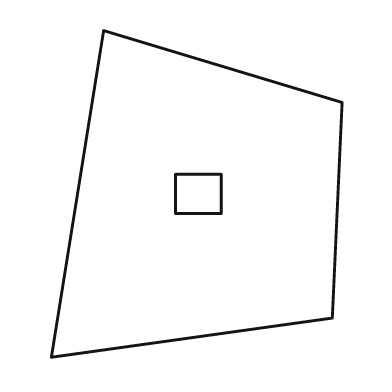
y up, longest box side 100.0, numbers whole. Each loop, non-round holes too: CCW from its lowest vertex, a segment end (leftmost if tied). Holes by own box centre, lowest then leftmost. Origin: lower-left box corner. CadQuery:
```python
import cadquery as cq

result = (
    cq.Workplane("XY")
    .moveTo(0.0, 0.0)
    .lineTo(86.0, 12.0)
    .lineTo(89.0, 78.0)
    .lineTo(16.0, 100.0)
    .close()
    .moveTo(38.0, 44.0)
    .lineTo(52.0, 44.0)
    .lineTo(52.0, 56.0)
    .lineTo(38.0, 56.0)
    .close()
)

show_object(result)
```